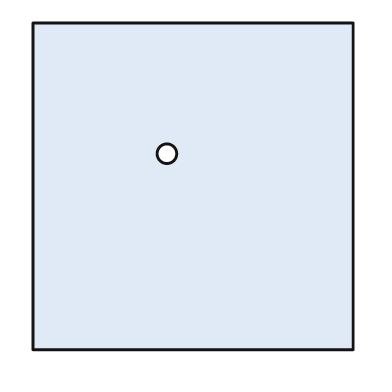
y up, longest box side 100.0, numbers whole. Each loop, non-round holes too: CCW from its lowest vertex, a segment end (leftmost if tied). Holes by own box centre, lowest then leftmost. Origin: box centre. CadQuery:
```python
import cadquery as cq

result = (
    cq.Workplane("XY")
    .moveTo(-49.0, -50.0)
    .lineTo(49.0, -50.0)
    .lineTo(49.0, 50.0)
    .lineTo(-49.0, 50.0)
    .close()
    .moveTo(-8.0, 10.0)
    .circle(3.0)
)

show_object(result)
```